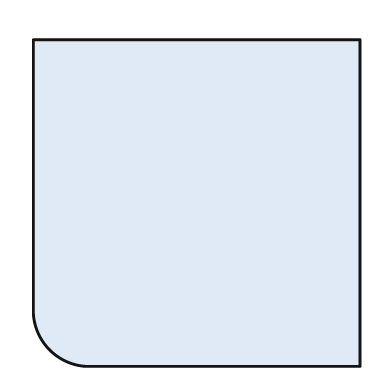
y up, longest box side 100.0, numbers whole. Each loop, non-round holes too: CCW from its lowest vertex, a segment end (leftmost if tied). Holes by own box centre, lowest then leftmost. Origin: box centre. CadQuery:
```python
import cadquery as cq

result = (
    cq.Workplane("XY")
    .moveTo(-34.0, -50.0)
    .lineTo(50.0, -50.0)
    .lineTo(50.0, 50.0)
    .lineTo(-50.0, 50.0)
    .lineTo(-50.0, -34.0)
    .threePointArc((-45.0, -45.0), (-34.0, -50.0))
    .close()
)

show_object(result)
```